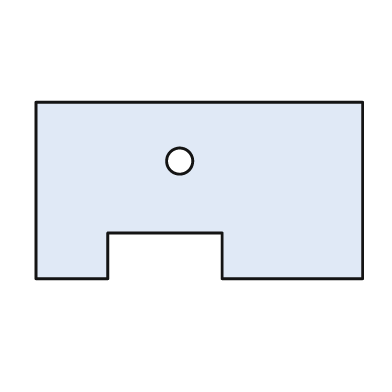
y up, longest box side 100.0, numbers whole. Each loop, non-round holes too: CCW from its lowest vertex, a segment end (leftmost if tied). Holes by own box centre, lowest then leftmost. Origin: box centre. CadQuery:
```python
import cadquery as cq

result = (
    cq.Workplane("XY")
    .moveTo(-50.0, -27.0)
    .lineTo(-28.0, -27.0)
    .lineTo(-28.0, -13.0)
    .lineTo(7.0, -13.0)
    .lineTo(7.0, -27.0)
    .lineTo(50.0, -27.0)
    .lineTo(50.0, 27.0)
    .lineTo(-50.0, 27.0)
    .close()
    .moveTo(-6.0, 9.0)
    .circle(4.0)
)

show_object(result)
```